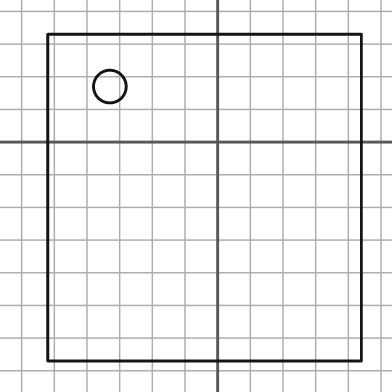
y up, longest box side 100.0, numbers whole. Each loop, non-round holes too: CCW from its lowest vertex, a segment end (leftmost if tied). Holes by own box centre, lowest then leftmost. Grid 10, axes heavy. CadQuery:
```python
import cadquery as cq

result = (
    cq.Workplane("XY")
    .moveTo(-52.0, -67.0)
    .lineTo(44.0, -67.0)
    .lineTo(44.0, 33.0)
    .lineTo(-52.0, 33.0)
    .close()
    .moveTo(-33.0, 17.0)
    .circle(5.0)
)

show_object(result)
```